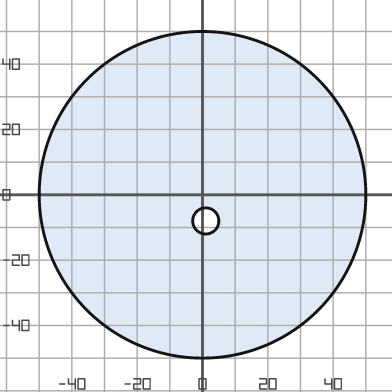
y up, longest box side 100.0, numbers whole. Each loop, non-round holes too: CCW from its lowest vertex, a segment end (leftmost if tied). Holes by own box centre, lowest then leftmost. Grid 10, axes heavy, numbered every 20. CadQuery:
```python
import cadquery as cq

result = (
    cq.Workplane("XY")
    .moveTo(0.0, 0.0)
    .circle(50.0)
    .moveTo(1.0, -8.0)
    .circle(4.0)
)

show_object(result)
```